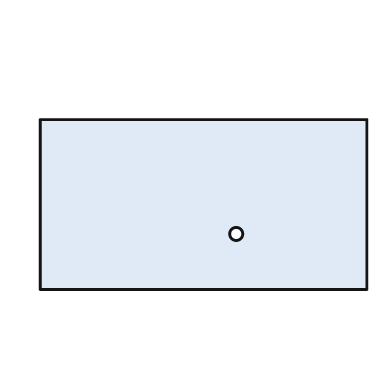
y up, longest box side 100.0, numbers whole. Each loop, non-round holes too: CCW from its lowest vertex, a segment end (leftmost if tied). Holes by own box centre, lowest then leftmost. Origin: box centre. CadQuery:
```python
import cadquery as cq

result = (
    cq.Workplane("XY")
    .moveTo(-50.0, -26.0)
    .lineTo(50.0, -26.0)
    .lineTo(50.0, 26.0)
    .lineTo(-50.0, 26.0)
    .close()
    .moveTo(10.0, -9.0)
    .circle(2.0)
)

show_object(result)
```